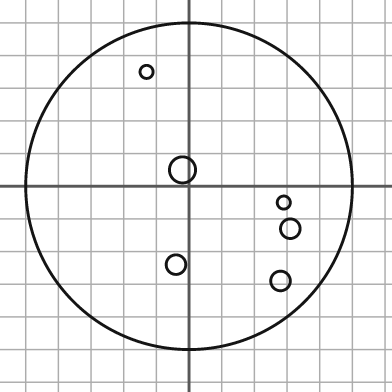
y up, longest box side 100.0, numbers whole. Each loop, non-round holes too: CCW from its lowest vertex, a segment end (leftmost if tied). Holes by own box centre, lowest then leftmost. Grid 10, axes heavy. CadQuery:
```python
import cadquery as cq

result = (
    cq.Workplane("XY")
    .moveTo(0.0, 0.0)
    .circle(50.0)
    .moveTo(28.0, -29.0)
    .circle(3.0)
    .moveTo(-4.0, -24.0)
    .circle(3.0)
    .moveTo(31.0, -13.0)
    .circle(3.0)
    .moveTo(29.0, -5.0)
    .circle(2.0)
    .moveTo(-2.0, 5.0)
    .circle(4.0)
    .moveTo(-13.0, 35.0)
    .circle(2.0)
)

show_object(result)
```